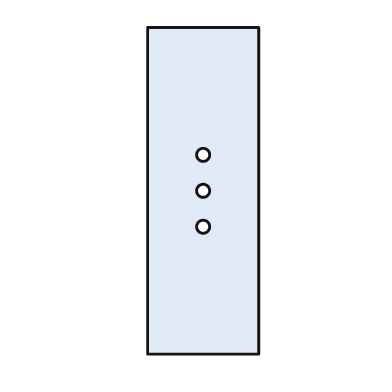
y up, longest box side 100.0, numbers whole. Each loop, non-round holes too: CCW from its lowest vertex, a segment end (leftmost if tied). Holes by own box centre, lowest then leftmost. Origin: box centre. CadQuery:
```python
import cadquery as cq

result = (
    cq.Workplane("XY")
    .moveTo(-17.0, -50.0)
    .lineTo(17.0, -50.0)
    .lineTo(17.0, 50.0)
    .lineTo(-17.0, 50.0)
    .close()
    .moveTo(0.0, -11.0)
    .circle(2.0)
    .moveTo(0.0, 0.0)
    .circle(2.0)
    .moveTo(0.0, 11.0)
    .circle(2.0)
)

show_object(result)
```